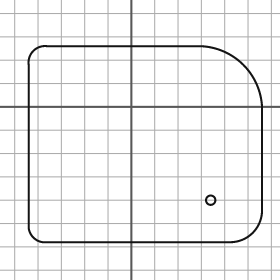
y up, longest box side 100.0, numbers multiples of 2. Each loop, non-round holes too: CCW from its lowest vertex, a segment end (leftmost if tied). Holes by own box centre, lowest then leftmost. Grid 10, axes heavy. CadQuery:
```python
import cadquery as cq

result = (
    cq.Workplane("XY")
    .moveTo(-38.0, -58.0)
    .lineTo(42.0, -58.0)
    .threePointArc((52.0, -54.0), (56.0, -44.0))
    .lineTo(56.0, 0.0)
    .threePointArc((48.0, 18.0), (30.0, 26.0))
    .lineTo(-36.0, 26.0)
    .threePointArc((-42.0, 24.0), (-44.0, 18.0))
    .lineTo(-44.0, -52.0)
    .threePointArc((-42.0, -56.0), (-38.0, -58.0))
    .close()
    .moveTo(34.0, -40.0)
    .circle(2.0)
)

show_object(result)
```